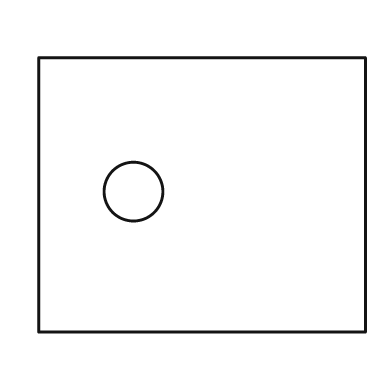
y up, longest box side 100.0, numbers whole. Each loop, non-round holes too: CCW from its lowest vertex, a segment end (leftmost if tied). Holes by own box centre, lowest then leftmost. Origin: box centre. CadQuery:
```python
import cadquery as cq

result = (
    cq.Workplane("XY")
    .moveTo(-50.0, -42.0)
    .lineTo(50.0, -42.0)
    .lineTo(50.0, 42.0)
    .lineTo(-50.0, 42.0)
    .close()
    .moveTo(-21.0, 1.0)
    .circle(9.0)
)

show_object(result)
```